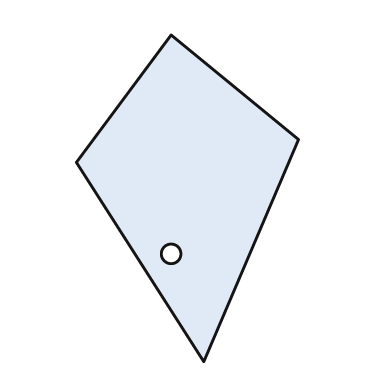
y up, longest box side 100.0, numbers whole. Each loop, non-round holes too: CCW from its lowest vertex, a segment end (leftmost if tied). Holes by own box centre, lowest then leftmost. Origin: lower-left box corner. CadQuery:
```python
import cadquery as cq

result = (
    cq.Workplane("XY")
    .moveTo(39.0, 0.0)
    .lineTo(68.0, 68.0)
    .lineTo(29.0, 100.0)
    .lineTo(0.0, 61.0)
    .close()
    .moveTo(29.0, 33.0)
    .circle(3.0)
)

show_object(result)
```